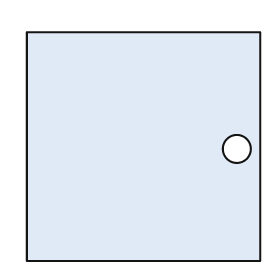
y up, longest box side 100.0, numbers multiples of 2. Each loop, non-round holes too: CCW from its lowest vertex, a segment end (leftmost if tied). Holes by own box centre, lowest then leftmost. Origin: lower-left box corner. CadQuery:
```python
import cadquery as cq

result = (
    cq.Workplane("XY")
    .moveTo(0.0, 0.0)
    .lineTo(100.0, 0.0)
    .lineTo(100.0, 98.0)
    .lineTo(0.0, 98.0)
    .close()
    .moveTo(90.0, 48.0)
    .circle(6.0)
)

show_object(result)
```